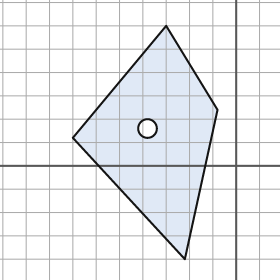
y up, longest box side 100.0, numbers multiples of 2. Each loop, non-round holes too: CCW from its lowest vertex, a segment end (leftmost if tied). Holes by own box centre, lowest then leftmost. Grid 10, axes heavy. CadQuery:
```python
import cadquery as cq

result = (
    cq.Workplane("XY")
    .moveTo(-22.0, -40.0)
    .lineTo(-8.0, 24.0)
    .lineTo(-30.0, 60.0)
    .lineTo(-70.0, 12.0)
    .close()
    .moveTo(-38.0, 16.0)
    .circle(4.0)
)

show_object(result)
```